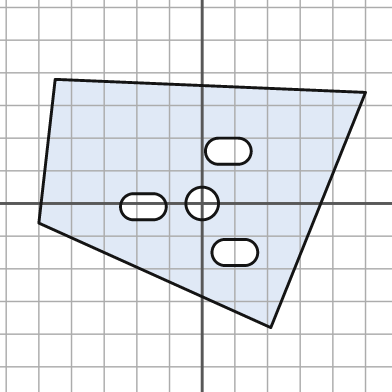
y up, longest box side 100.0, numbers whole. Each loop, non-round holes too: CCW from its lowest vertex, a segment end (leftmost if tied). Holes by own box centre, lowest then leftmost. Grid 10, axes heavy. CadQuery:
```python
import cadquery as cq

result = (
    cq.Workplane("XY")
    .moveTo(21.0, -38.0)
    .lineTo(50.0, 34.0)
    .lineTo(-45.0, 38.0)
    .lineTo(-50.0, -6.0)
    .close()
    .moveTo(7.0, -19.0)
    .lineTo(13.0, -19.0)
    .threePointArc((17.0, -15.0), (13.0, -11.0))
    .lineTo(7.0, -11.0)
    .threePointArc((3.0, -15.0), (7.0, -19.0))
    .close()
    .moveTo(-21.0, -5.0)
    .lineTo(-15.0, -5.0)
    .threePointArc((-11.0, -1.0), (-15.0, 3.0))
    .lineTo(-21.0, 3.0)
    .threePointArc((-25.0, -1.0), (-21.0, -5.0))
    .close()
    .moveTo(0.0, 0.0)
    .circle(5.0)
    .moveTo(5.0, 12.0)
    .lineTo(11.0, 12.0)
    .threePointArc((15.0, 16.0), (11.0, 20.0))
    .lineTo(5.0, 20.0)
    .threePointArc((1.0, 16.0), (5.0, 12.0))
    .close()
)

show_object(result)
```